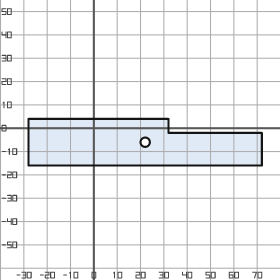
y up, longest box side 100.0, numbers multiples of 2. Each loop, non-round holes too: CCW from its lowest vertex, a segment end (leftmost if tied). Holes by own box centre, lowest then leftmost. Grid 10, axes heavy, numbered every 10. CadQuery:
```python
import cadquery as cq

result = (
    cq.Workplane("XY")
    .moveTo(-28.0, -16.0)
    .lineTo(72.0, -16.0)
    .lineTo(72.0, -2.0)
    .lineTo(32.0, -2.0)
    .lineTo(32.0, 4.0)
    .lineTo(-28.0, 4.0)
    .close()
    .moveTo(22.0, -6.0)
    .circle(2.0)
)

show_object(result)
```